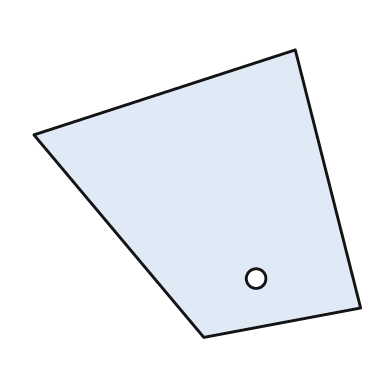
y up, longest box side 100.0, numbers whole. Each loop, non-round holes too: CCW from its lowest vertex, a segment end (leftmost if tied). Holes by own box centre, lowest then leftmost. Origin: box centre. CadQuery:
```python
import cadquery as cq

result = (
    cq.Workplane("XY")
    .moveTo(2.0, -44.0)
    .lineTo(50.0, -35.0)
    .lineTo(30.0, 44.0)
    .lineTo(-50.0, 18.0)
    .close()
    .moveTo(18.0, -26.0)
    .circle(3.0)
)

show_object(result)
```